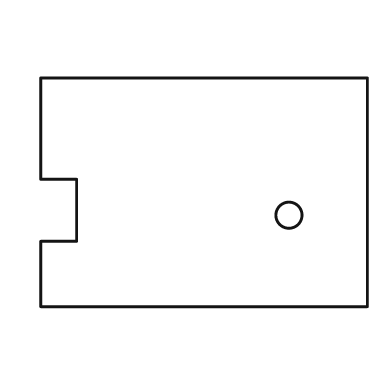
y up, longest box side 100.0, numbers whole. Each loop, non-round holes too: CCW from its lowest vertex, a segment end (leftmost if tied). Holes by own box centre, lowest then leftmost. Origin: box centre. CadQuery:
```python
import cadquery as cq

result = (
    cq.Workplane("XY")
    .moveTo(-50.0, -35.0)
    .lineTo(50.0, -35.0)
    .lineTo(50.0, 35.0)
    .lineTo(-50.0, 35.0)
    .lineTo(-50.0, 4.0)
    .lineTo(-39.0, 4.0)
    .lineTo(-39.0, -15.0)
    .lineTo(-50.0, -15.0)
    .close()
    .moveTo(26.0, -7.0)
    .circle(4.0)
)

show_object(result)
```